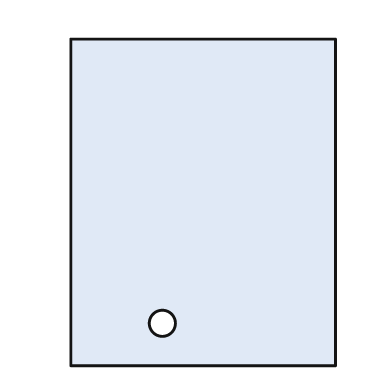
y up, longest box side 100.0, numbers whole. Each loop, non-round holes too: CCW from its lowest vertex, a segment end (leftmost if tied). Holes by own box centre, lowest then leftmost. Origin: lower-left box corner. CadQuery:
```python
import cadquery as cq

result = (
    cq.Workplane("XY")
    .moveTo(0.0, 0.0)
    .lineTo(81.0, 0.0)
    .lineTo(81.0, 100.0)
    .lineTo(0.0, 100.0)
    .close()
    .moveTo(28.0, 13.0)
    .circle(4.0)
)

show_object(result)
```